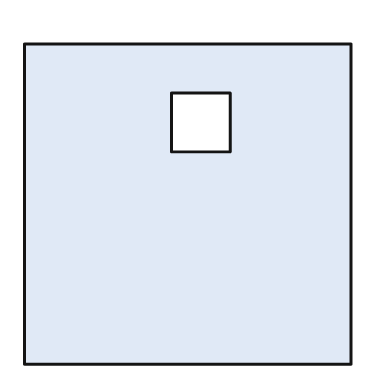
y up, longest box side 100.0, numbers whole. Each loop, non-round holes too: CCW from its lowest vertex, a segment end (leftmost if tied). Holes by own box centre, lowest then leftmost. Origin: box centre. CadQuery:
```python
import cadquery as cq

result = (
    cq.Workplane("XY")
    .moveTo(-50.0, -49.0)
    .lineTo(50.0, -49.0)
    .lineTo(50.0, 49.0)
    .lineTo(-50.0, 49.0)
    .close()
    .moveTo(-5.0, 16.0)
    .lineTo(13.0, 16.0)
    .lineTo(13.0, 34.0)
    .lineTo(-5.0, 34.0)
    .close()
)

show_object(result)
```